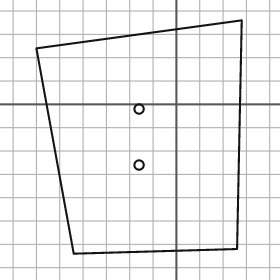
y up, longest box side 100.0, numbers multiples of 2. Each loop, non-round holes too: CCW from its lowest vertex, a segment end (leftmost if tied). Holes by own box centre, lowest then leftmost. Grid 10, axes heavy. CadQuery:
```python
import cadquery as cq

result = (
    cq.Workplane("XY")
    .moveTo(-44.0, -64.0)
    .lineTo(26.0, -62.0)
    .lineTo(28.0, 36.0)
    .lineTo(-60.0, 24.0)
    .close()
    .moveTo(-16.0, -26.0)
    .circle(2.0)
    .moveTo(-16.0, -2.0)
    .circle(2.0)
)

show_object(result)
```